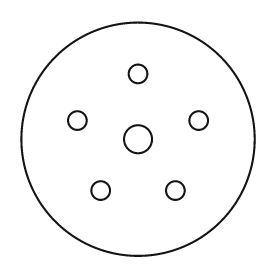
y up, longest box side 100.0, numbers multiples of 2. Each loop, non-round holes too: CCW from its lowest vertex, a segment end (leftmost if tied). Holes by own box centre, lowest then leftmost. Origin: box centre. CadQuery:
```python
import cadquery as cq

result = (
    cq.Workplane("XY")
    .moveTo(0.0, 0.0)
    .circle(50.0)
    .moveTo(-16.0, -22.0)
    .circle(4.0)
    .moveTo(16.0, -22.0)
    .circle(4.0)
    .moveTo(0.0, 0.0)
    .circle(6.0)
    .moveTo(-26.0, 8.0)
    .circle(4.0)
    .moveTo(26.0, 8.0)
    .circle(4.0)
    .moveTo(0.0, 28.0)
    .circle(4.0)
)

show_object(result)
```